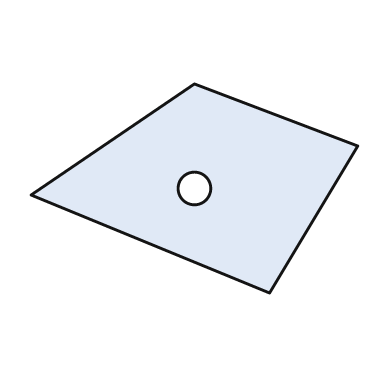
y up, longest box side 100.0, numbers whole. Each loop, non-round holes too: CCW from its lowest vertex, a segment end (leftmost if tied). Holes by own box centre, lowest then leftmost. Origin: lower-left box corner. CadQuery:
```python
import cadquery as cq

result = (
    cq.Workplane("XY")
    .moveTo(73.0, 0.0)
    .lineTo(100.0, 45.0)
    .lineTo(50.0, 64.0)
    .lineTo(0.0, 30.0)
    .close()
    .moveTo(50.0, 32.0)
    .circle(5.0)
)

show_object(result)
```